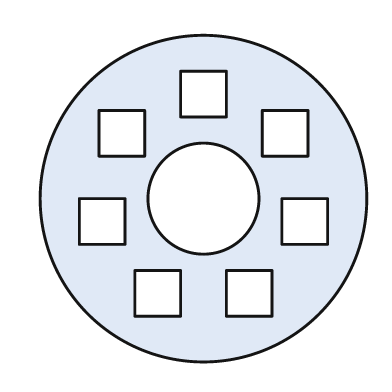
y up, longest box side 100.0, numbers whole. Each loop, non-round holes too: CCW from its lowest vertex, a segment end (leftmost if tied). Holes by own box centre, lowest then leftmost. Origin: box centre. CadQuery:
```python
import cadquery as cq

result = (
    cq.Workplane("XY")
    .moveTo(0.0, 0.0)
    .circle(50.0)
    .moveTo(-21.0, -36.0)
    .lineTo(-7.0, -36.0)
    .lineTo(-7.0, -22.0)
    .lineTo(-21.0, -22.0)
    .close()
    .moveTo(7.0, -36.0)
    .lineTo(21.0, -36.0)
    .lineTo(21.0, -22.0)
    .lineTo(7.0, -22.0)
    .close()
    .moveTo(-38.0, -14.0)
    .lineTo(-24.0, -14.0)
    .lineTo(-24.0, 0.0)
    .lineTo(-38.0, 0.0)
    .close()
    .moveTo(24.0, -14.0)
    .lineTo(38.0, -14.0)
    .lineTo(38.0, 0.0)
    .lineTo(24.0, 0.0)
    .close()
    .moveTo(0.0, 0.0)
    .circle(17.0)
    .moveTo(-32.0, 13.0)
    .lineTo(-18.0, 13.0)
    .lineTo(-18.0, 27.0)
    .lineTo(-32.0, 27.0)
    .close()
    .moveTo(18.0, 13.0)
    .lineTo(32.0, 13.0)
    .lineTo(32.0, 27.0)
    .lineTo(18.0, 27.0)
    .close()
    .moveTo(-7.0, 25.0)
    .lineTo(7.0, 25.0)
    .lineTo(7.0, 39.0)
    .lineTo(-7.0, 39.0)
    .close()
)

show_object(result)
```